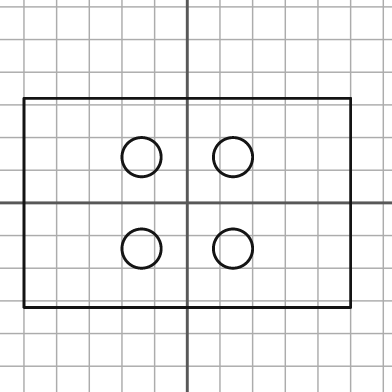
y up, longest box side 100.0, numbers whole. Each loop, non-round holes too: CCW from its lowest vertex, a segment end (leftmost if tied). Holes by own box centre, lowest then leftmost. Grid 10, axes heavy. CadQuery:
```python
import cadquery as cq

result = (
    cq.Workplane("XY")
    .moveTo(-50.0, -32.0)
    .lineTo(50.0, -32.0)
    .lineTo(50.0, 32.0)
    .lineTo(-50.0, 32.0)
    .close()
    .moveTo(-14.0, -14.0)
    .circle(6.0)
    .moveTo(14.0, -14.0)
    .circle(6.0)
    .moveTo(-14.0, 14.0)
    .circle(6.0)
    .moveTo(14.0, 14.0)
    .circle(6.0)
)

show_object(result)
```